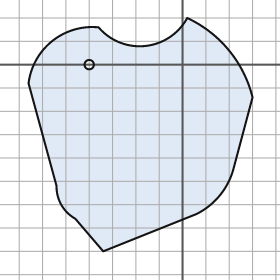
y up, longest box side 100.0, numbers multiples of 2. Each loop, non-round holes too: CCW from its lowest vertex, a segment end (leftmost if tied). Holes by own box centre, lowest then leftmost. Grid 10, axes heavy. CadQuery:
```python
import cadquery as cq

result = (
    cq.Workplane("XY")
    .moveTo(-34.0, -80.0)
    .lineTo(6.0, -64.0)
    .threePointArc((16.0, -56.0), (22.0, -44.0))
    .lineTo(30.0, -14.0)
    .threePointArc((20.0, 6.0), (2.0, 20.0))
    .threePointArc((-16.0, 8.0), (-36.0, 16.0))
    .threePointArc((-56.0, 10.0), (-66.0, -8.0))
    .lineTo(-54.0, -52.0)
    .threePointArc((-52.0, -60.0), (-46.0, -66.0))
    .close()
    .moveTo(-40.0, 0.0)
    .circle(2.0)
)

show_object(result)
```